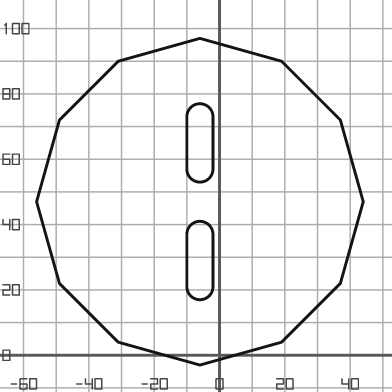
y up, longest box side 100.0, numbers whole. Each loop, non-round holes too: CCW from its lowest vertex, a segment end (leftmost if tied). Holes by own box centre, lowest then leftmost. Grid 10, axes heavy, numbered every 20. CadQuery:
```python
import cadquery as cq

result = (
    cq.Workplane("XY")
    .moveTo(-6.0, -3.0)
    .lineTo(19.0, 4.0)
    .lineTo(37.0, 22.0)
    .lineTo(44.0, 47.0)
    .lineTo(37.0, 72.0)
    .lineTo(19.0, 90.0)
    .lineTo(-6.0, 97.0)
    .lineTo(-31.0, 90.0)
    .lineTo(-49.0, 72.0)
    .lineTo(-56.0, 47.0)
    .lineTo(-49.0, 22.0)
    .lineTo(-31.0, 4.0)
    .close()
    .moveTo(-10.0, 21.0)
    .threePointArc((-6.0, 17.0), (-2.0, 21.0))
    .lineTo(-2.0, 37.0)
    .threePointArc((-6.0, 41.0), (-10.0, 37.0))
    .close()
    .moveTo(-10.0, 57.0)
    .threePointArc((-6.0, 53.0), (-2.0, 57.0))
    .lineTo(-2.0, 73.0)
    .threePointArc((-6.0, 77.0), (-10.0, 73.0))
    .close()
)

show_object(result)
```